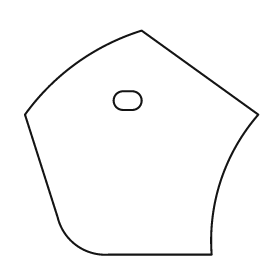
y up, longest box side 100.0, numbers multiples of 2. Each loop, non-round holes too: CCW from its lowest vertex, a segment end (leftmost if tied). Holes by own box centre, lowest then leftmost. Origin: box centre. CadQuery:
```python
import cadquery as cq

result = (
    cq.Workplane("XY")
    .moveTo(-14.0, -48.0)
    .lineTo(30.0, -48.0)
    .threePointArc((34.0, -16.0), (50.0, 12.0))
    .lineTo(0.0, 48.0)
    .threePointArc((-28.0, 34.0), (-50.0, 12.0))
    .lineTo(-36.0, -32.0)
    .threePointArc((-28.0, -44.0), (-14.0, -48.0))
    .close()
    .moveTo(-8.0, 14.0)
    .lineTo(-4.0, 14.0)
    .threePointArc((0.0, 18.0), (-4.0, 22.0))
    .lineTo(-8.0, 22.0)
    .threePointArc((-12.0, 18.0), (-8.0, 14.0))
    .close()
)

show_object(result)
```